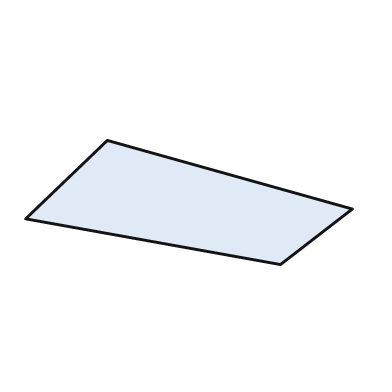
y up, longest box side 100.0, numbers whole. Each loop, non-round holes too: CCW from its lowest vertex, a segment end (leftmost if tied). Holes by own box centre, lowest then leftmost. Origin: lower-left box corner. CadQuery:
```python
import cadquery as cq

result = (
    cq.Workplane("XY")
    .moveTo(78.0, 0.0)
    .lineTo(100.0, 17.0)
    .lineTo(25.0, 38.0)
    .lineTo(0.0, 14.0)
    .close()
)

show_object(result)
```